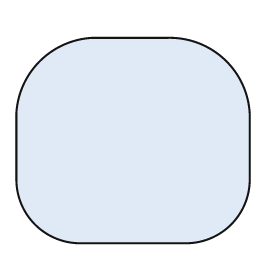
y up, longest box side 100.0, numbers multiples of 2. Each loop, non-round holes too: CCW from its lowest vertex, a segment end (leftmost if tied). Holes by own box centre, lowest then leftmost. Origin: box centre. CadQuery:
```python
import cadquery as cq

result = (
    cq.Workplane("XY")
    .moveTo(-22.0, -44.0)
    .lineTo(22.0, -44.0)
    .threePointArc((42.0, -36.0), (50.0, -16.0))
    .lineTo(50.0, 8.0)
    .threePointArc((40.0, 34.0), (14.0, 44.0))
    .lineTo(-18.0, 44.0)
    .threePointArc((-40.0, 34.0), (-50.0, 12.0))
    .lineTo(-50.0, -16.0)
    .threePointArc((-42.0, -36.0), (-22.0, -44.0))
    .close()
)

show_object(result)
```